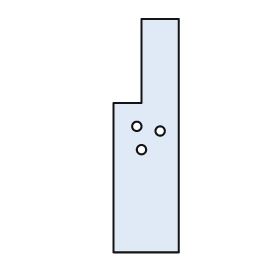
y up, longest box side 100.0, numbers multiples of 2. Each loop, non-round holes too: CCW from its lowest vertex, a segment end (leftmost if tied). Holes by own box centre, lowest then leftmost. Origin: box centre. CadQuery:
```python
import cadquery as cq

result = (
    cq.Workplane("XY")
    .moveTo(-14.0, -50.0)
    .lineTo(14.0, -50.0)
    .lineTo(14.0, 50.0)
    .lineTo(-2.0, 50.0)
    .lineTo(-2.0, 14.0)
    .lineTo(-14.0, 14.0)
    .close()
    .moveTo(-2.0, -6.0)
    .circle(2.0)
    .moveTo(6.0, 2.0)
    .circle(2.0)
    .moveTo(-4.0, 4.0)
    .circle(2.0)
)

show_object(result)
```